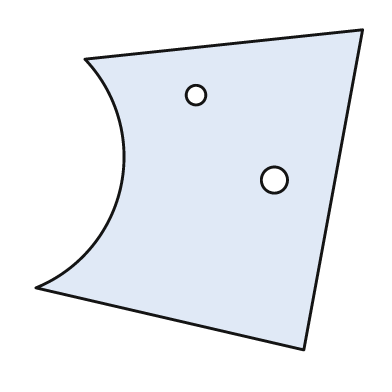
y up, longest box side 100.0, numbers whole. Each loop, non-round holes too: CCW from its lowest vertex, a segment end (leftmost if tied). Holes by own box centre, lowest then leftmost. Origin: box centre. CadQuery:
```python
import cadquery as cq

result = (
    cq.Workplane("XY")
    .moveTo(32.0, -49.0)
    .lineTo(50.0, 49.0)
    .lineTo(-35.0, 40.0)
    .threePointArc((-24.0, 1.0), (-50.0, -30.0))
    .close()
    .moveTo(23.0, 3.0)
    .circle(4.0)
    .moveTo(-1.0, 29.0)
    .circle(3.0)
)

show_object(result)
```